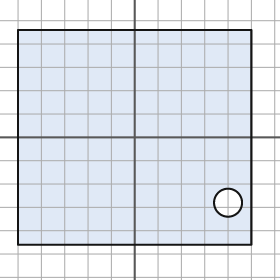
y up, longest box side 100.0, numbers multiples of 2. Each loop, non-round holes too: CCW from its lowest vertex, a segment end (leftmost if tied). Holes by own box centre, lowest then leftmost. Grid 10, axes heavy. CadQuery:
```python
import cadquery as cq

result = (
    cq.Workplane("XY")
    .moveTo(-50.0, -46.0)
    .lineTo(50.0, -46.0)
    .lineTo(50.0, 46.0)
    .lineTo(-50.0, 46.0)
    .close()
    .moveTo(40.0, -28.0)
    .circle(6.0)
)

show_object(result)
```